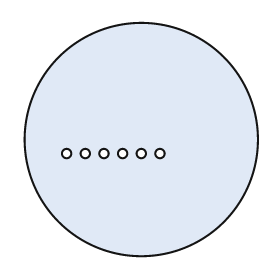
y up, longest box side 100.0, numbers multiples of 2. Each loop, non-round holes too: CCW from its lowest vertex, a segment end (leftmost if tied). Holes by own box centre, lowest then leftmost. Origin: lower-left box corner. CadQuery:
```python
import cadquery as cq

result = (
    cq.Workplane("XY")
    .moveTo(50.0, 50.0)
    .circle(50.0)
    .moveTo(18.0, 44.0)
    .circle(2.0)
    .moveTo(26.0, 44.0)
    .circle(2.0)
    .moveTo(34.0, 44.0)
    .circle(2.0)
    .moveTo(42.0, 44.0)
    .circle(2.0)
    .moveTo(50.0, 44.0)
    .circle(2.0)
    .moveTo(58.0, 44.0)
    .circle(2.0)
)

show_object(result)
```